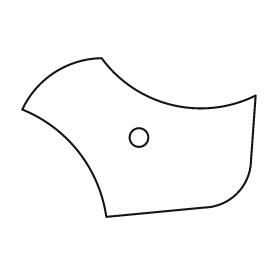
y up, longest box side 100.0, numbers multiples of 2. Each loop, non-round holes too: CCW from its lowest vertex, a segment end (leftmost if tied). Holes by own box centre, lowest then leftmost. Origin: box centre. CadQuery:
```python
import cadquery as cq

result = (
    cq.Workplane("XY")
    .moveTo(-14.0, -34.0)
    .lineTo(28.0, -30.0)
    .threePointArc((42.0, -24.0), (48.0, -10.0))
    .lineTo(50.0, 18.0)
    .threePointArc((14.0, 14.0), (-16.0, 34.0))
    .threePointArc((-36.0, 28.0), (-50.0, 12.0))
    .threePointArc((-26.0, -6.0), (-14.0, -34.0))
    .close()
    .moveTo(0.0, 0.0)
    .circle(4.0)
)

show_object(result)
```